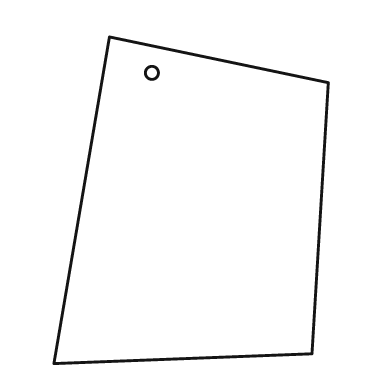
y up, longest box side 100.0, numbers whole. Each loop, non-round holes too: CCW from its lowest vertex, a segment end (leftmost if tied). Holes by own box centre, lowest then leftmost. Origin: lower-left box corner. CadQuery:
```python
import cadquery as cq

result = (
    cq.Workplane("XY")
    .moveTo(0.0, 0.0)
    .lineTo(79.0, 3.0)
    .lineTo(84.0, 86.0)
    .lineTo(17.0, 100.0)
    .close()
    .moveTo(30.0, 89.0)
    .circle(2.0)
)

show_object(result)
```